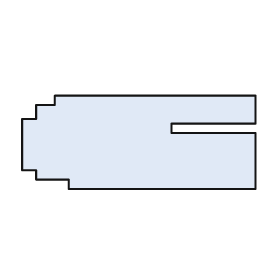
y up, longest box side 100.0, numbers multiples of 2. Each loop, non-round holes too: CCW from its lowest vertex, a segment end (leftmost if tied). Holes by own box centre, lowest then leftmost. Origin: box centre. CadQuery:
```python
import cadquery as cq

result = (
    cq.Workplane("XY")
    .moveTo(-30.0, -20.0)
    .lineTo(50.0, -20.0)
    .lineTo(50.0, 4.0)
    .lineTo(14.0, 4.0)
    .lineTo(14.0, 8.0)
    .lineTo(50.0, 8.0)
    .lineTo(50.0, 20.0)
    .lineTo(-36.0, 20.0)
    .lineTo(-36.0, 16.0)
    .lineTo(-44.0, 16.0)
    .lineTo(-44.0, 10.0)
    .lineTo(-50.0, 10.0)
    .lineTo(-50.0, -12.0)
    .lineTo(-44.0, -12.0)
    .lineTo(-44.0, -16.0)
    .lineTo(-30.0, -16.0)
    .close()
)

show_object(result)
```